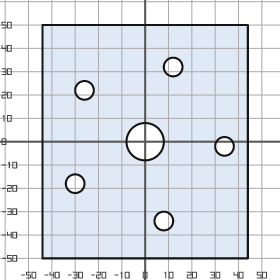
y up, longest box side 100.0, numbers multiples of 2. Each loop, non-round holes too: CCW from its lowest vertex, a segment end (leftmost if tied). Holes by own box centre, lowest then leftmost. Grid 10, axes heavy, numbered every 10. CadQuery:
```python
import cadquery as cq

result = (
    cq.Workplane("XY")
    .moveTo(-44.0, -50.0)
    .lineTo(44.0, -50.0)
    .lineTo(44.0, 50.0)
    .lineTo(-44.0, 50.0)
    .close()
    .moveTo(8.0, -34.0)
    .circle(4.0)
    .moveTo(-30.0, -18.0)
    .circle(4.0)
    .moveTo(34.0, -2.0)
    .circle(4.0)
    .moveTo(0.0, 0.0)
    .circle(8.0)
    .moveTo(-26.0, 22.0)
    .circle(4.0)
    .moveTo(12.0, 32.0)
    .circle(4.0)
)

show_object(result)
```